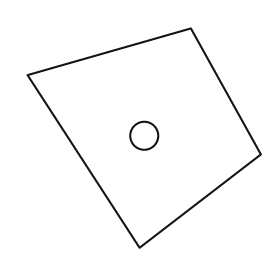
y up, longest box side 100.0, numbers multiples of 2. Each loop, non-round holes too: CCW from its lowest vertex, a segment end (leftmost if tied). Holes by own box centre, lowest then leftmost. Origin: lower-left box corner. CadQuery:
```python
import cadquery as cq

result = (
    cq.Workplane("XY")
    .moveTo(48.0, 0.0)
    .lineTo(100.0, 40.0)
    .lineTo(70.0, 94.0)
    .lineTo(0.0, 74.0)
    .close()
    .moveTo(50.0, 48.0)
    .circle(6.0)
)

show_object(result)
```